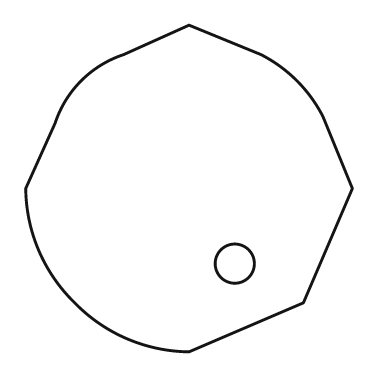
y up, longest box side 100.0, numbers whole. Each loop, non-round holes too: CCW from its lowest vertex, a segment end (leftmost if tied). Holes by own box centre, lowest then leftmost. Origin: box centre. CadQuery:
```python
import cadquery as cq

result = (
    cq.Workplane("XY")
    .moveTo(0.0, -50.0)
    .lineTo(35.0, -35.0)
    .lineTo(50.0, 0.0)
    .lineTo(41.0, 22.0)
    .threePointArc((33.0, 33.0), (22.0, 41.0))
    .lineTo(0.0, 50.0)
    .lineTo(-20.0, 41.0)
    .threePointArc((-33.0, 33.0), (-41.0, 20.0))
    .lineTo(-50.0, 0.0)
    .threePointArc((-46.0, -19.0), (-35.0, -35.0))
    .threePointArc((-19.0, -46.0), (0.0, -50.0))
    .close()
    .moveTo(14.0, -23.0)
    .circle(6.0)
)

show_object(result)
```